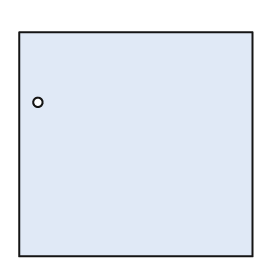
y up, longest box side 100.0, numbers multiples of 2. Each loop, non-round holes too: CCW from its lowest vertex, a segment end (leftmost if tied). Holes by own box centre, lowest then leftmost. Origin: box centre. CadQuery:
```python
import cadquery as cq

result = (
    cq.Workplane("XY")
    .moveTo(-50.0, -48.0)
    .lineTo(50.0, -48.0)
    .lineTo(50.0, 48.0)
    .lineTo(-50.0, 48.0)
    .close()
    .moveTo(-42.0, 18.0)
    .circle(2.0)
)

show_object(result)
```